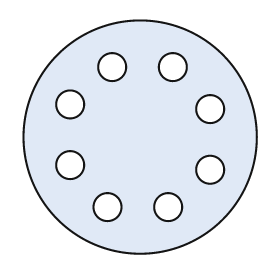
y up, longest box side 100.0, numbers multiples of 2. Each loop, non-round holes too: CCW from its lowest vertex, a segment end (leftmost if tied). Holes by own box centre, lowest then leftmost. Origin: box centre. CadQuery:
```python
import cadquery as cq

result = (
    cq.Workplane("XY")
    .moveTo(0.0, 0.0)
    .circle(50.0)
    .moveTo(-14.0, -30.0)
    .circle(6.0)
    .moveTo(12.0, -30.0)
    .circle(6.0)
    .moveTo(30.0, -14.0)
    .circle(6.0)
    .moveTo(-30.0, -12.0)
    .circle(6.0)
    .moveTo(30.0, 12.0)
    .circle(6.0)
    .moveTo(-30.0, 14.0)
    .circle(6.0)
    .moveTo(-12.0, 30.0)
    .circle(6.0)
    .moveTo(14.0, 30.0)
    .circle(6.0)
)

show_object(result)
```